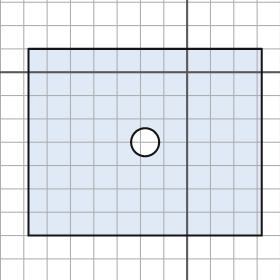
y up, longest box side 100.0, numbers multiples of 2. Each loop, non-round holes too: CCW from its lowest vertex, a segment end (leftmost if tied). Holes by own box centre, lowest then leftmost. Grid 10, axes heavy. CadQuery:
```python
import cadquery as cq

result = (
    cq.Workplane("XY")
    .moveTo(-68.0, -70.0)
    .lineTo(32.0, -70.0)
    .lineTo(32.0, 10.0)
    .lineTo(-68.0, 10.0)
    .close()
    .moveTo(-18.0, -30.0)
    .circle(6.0)
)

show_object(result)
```